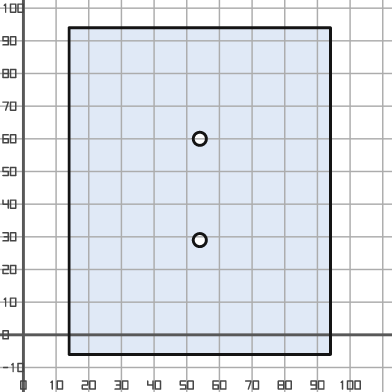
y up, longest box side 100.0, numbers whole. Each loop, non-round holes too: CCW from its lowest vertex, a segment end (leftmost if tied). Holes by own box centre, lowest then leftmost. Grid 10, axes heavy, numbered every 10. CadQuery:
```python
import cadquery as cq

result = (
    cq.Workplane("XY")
    .moveTo(14.0, -6.0)
    .lineTo(94.0, -6.0)
    .lineTo(94.0, 94.0)
    .lineTo(14.0, 94.0)
    .close()
    .moveTo(54.0, 29.0)
    .circle(2.0)
    .moveTo(54.0, 60.0)
    .circle(2.0)
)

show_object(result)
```